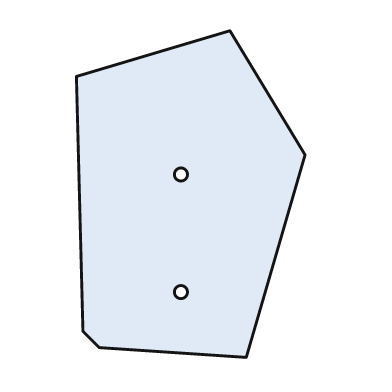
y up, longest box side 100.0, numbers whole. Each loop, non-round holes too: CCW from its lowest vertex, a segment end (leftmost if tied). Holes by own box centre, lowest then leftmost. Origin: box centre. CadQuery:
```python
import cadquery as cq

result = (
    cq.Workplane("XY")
    .moveTo(17.0, -50.0)
    .lineTo(35.0, 12.0)
    .lineTo(12.0, 50.0)
    .lineTo(-35.0, 36.0)
    .lineTo(-33.0, -42.0)
    .lineTo(-28.0, -47.0)
    .close()
    .moveTo(-3.0, -30.0)
    .circle(2.0)
    .moveTo(-3.0, 6.0)
    .circle(2.0)
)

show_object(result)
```